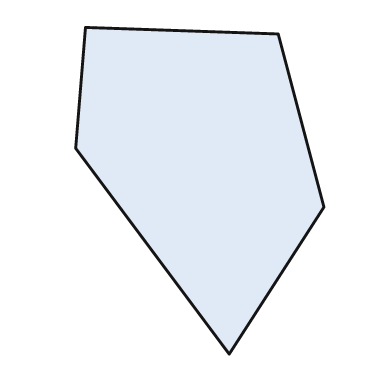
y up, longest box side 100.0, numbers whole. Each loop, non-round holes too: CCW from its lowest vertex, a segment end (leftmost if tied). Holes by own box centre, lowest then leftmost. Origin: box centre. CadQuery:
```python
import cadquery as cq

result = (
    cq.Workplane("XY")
    .moveTo(9.0, -50.0)
    .lineTo(38.0, -5.0)
    .lineTo(24.0, 48.0)
    .lineTo(-35.0, 50.0)
    .lineTo(-38.0, 13.0)
    .close()
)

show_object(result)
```